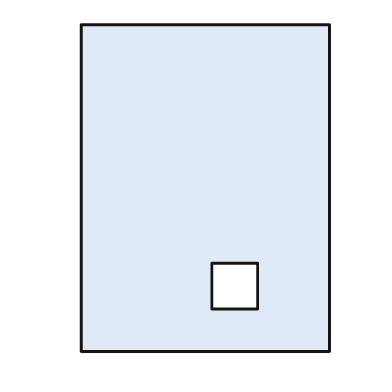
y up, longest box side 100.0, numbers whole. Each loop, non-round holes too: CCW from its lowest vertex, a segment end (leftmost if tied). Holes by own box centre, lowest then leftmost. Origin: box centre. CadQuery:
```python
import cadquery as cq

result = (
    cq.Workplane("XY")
    .moveTo(-38.0, -50.0)
    .lineTo(38.0, -50.0)
    .lineTo(38.0, 50.0)
    .lineTo(-38.0, 50.0)
    .close()
    .moveTo(2.0, -37.0)
    .lineTo(16.0, -37.0)
    .lineTo(16.0, -23.0)
    .lineTo(2.0, -23.0)
    .close()
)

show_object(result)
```